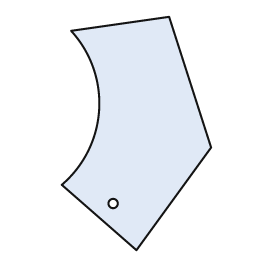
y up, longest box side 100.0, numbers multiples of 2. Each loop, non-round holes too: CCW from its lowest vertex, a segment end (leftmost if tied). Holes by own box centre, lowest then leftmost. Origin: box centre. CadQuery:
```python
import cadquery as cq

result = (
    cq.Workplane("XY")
    .moveTo(0.0, -50.0)
    .lineTo(32.0, -6.0)
    .lineTo(14.0, 50.0)
    .lineTo(-28.0, 44.0)
    .threePointArc((-16.0, 10.0), (-32.0, -22.0))
    .close()
    .moveTo(-10.0, -30.0)
    .circle(2.0)
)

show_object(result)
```